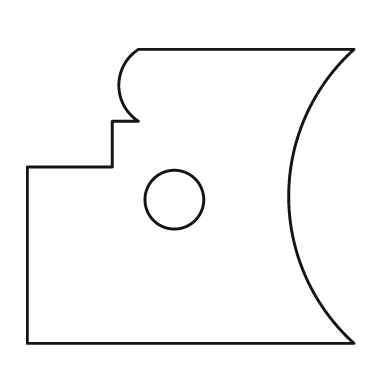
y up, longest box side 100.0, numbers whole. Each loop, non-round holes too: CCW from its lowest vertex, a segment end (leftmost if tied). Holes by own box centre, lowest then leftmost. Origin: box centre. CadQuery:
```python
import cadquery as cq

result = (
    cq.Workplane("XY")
    .moveTo(-50.0, -45.0)
    .lineTo(50.0, -45.0)
    .threePointArc((30.0, 0.0), (50.0, 45.0))
    .lineTo(-16.0, 45.0)
    .threePointArc((-22.0, 34.0), (-16.0, 23.0))
    .lineTo(-24.0, 23.0)
    .lineTo(-24.0, 9.0)
    .lineTo(-50.0, 9.0)
    .close()
    .moveTo(-5.0, -1.0)
    .circle(9.0)
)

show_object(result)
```